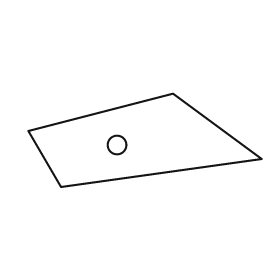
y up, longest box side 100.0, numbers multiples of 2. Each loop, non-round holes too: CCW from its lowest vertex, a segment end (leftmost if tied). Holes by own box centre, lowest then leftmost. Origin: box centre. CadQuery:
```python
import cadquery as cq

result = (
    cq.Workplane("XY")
    .moveTo(-36.0, -20.0)
    .lineTo(50.0, -8.0)
    .lineTo(12.0, 20.0)
    .lineTo(-50.0, 4.0)
    .close()
    .moveTo(-12.0, -2.0)
    .circle(4.0)
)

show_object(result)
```